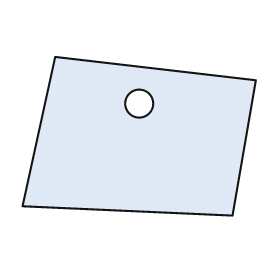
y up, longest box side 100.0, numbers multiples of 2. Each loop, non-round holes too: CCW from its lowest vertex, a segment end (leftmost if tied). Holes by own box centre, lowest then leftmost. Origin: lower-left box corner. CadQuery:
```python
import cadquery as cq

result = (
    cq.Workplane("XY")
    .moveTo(90.0, 0.0)
    .lineTo(100.0, 58.0)
    .lineTo(14.0, 68.0)
    .lineTo(0.0, 4.0)
    .close()
    .moveTo(50.0, 48.0)
    .circle(6.0)
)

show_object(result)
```